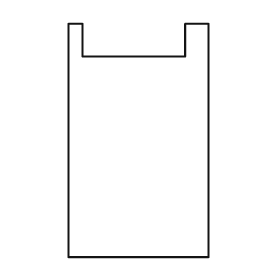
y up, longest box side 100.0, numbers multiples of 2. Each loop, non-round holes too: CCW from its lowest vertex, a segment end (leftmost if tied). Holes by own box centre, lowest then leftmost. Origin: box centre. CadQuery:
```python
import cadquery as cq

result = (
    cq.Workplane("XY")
    .moveTo(-30.0, -50.0)
    .lineTo(30.0, -50.0)
    .lineTo(30.0, 50.0)
    .lineTo(20.0, 50.0)
    .lineTo(20.0, 36.0)
    .lineTo(-24.0, 36.0)
    .lineTo(-24.0, 50.0)
    .lineTo(-30.0, 50.0)
    .close()
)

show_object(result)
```